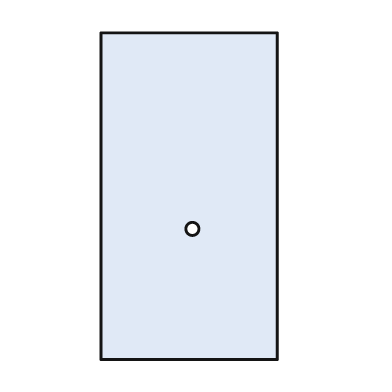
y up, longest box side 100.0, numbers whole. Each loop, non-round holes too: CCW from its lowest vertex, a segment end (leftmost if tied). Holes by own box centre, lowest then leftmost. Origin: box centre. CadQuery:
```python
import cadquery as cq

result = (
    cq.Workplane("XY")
    .moveTo(-27.0, -50.0)
    .lineTo(27.0, -50.0)
    .lineTo(27.0, 50.0)
    .lineTo(-27.0, 50.0)
    .close()
    .moveTo(1.0, -10.0)
    .circle(2.0)
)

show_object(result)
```